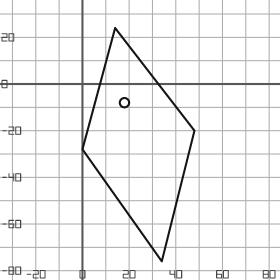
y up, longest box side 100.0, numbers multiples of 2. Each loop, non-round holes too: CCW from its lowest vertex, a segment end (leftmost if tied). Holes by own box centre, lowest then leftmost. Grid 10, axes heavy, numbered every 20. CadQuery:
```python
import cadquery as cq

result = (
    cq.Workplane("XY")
    .moveTo(34.0, -76.0)
    .lineTo(48.0, -20.0)
    .lineTo(14.0, 24.0)
    .lineTo(0.0, -28.0)
    .close()
    .moveTo(18.0, -8.0)
    .circle(2.0)
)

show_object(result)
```